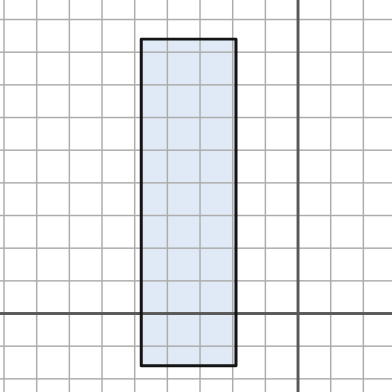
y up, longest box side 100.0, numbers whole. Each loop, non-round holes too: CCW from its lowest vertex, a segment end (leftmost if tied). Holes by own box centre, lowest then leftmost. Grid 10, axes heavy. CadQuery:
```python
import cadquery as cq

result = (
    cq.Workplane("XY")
    .moveTo(-48.0, -16.0)
    .lineTo(-19.0, -16.0)
    .lineTo(-19.0, 84.0)
    .lineTo(-48.0, 84.0)
    .close()
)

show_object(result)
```